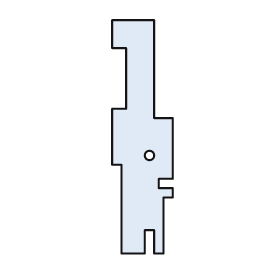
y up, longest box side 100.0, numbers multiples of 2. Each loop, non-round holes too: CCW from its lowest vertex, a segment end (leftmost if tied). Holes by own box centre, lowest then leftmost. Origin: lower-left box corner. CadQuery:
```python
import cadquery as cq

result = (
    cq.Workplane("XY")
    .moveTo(4.0, 0.0)
    .lineTo(14.0, 0.0)
    .lineTo(14.0, 10.0)
    .lineTo(18.0, 10.0)
    .lineTo(18.0, 0.0)
    .lineTo(22.0, 0.0)
    .lineTo(22.0, 24.0)
    .lineTo(26.0, 24.0)
    .lineTo(26.0, 28.0)
    .lineTo(20.0, 28.0)
    .lineTo(20.0, 32.0)
    .lineTo(26.0, 32.0)
    .lineTo(26.0, 58.0)
    .lineTo(18.0, 58.0)
    .lineTo(18.0, 100.0)
    .lineTo(0.0, 100.0)
    .lineTo(0.0, 88.0)
    .lineTo(6.0, 88.0)
    .lineTo(6.0, 62.0)
    .lineTo(0.0, 62.0)
    .lineTo(0.0, 38.0)
    .lineTo(4.0, 38.0)
    .close()
    .moveTo(16.0, 42.0)
    .circle(2.0)
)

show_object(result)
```